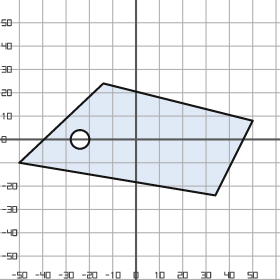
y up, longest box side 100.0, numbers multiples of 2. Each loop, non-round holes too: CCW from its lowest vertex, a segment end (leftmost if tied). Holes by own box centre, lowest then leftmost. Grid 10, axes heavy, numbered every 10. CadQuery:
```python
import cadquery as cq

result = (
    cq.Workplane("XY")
    .moveTo(34.0, -24.0)
    .lineTo(50.0, 8.0)
    .lineTo(-14.0, 24.0)
    .lineTo(-50.0, -10.0)
    .close()
    .moveTo(-24.0, 0.0)
    .circle(4.0)
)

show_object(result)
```